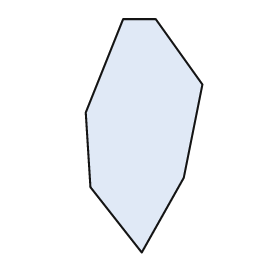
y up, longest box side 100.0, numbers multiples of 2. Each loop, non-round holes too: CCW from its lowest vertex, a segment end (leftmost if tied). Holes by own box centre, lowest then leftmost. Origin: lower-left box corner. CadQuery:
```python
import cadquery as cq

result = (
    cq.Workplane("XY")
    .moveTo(24.0, 0.0)
    .lineTo(42.0, 32.0)
    .lineTo(50.0, 72.0)
    .lineTo(30.0, 100.0)
    .lineTo(16.0, 100.0)
    .lineTo(0.0, 60.0)
    .lineTo(2.0, 28.0)
    .close()
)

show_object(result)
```